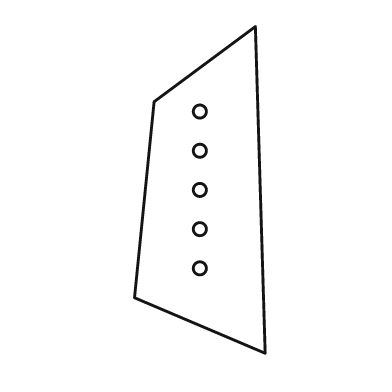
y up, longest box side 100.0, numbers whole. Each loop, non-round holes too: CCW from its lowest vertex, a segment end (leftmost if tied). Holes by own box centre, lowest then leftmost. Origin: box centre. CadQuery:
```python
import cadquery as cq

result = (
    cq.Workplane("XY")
    .moveTo(20.0, -50.0)
    .lineTo(17.0, 50.0)
    .lineTo(-14.0, 27.0)
    .lineTo(-20.0, -33.0)
    .close()
    .moveTo(0.0, -24.0)
    .circle(2.0)
    .moveTo(0.0, -12.0)
    .circle(2.0)
    .moveTo(0.0, 0.0)
    .circle(2.0)
    .moveTo(0.0, 12.0)
    .circle(2.0)
    .moveTo(0.0, 24.0)
    .circle(2.0)
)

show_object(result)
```